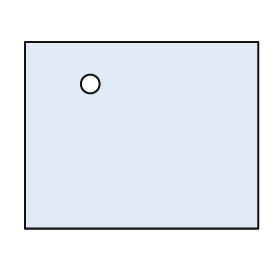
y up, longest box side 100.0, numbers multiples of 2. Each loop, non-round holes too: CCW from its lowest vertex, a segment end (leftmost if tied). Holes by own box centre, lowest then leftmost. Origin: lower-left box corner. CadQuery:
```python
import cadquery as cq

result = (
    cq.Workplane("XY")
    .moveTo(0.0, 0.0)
    .lineTo(100.0, 0.0)
    .lineTo(100.0, 80.0)
    .lineTo(0.0, 80.0)
    .close()
    .moveTo(28.0, 62.0)
    .circle(4.0)
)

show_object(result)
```